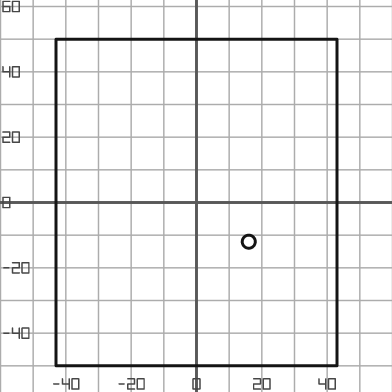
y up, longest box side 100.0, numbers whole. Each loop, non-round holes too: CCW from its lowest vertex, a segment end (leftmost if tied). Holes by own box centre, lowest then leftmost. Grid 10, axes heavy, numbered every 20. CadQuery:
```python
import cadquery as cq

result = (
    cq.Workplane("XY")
    .moveTo(-43.0, -50.0)
    .lineTo(43.0, -50.0)
    .lineTo(43.0, 50.0)
    .lineTo(-43.0, 50.0)
    .close()
    .moveTo(16.0, -12.0)
    .circle(2.0)
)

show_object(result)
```